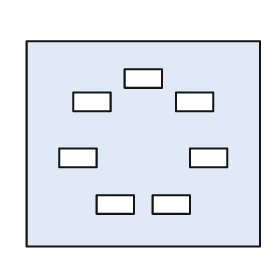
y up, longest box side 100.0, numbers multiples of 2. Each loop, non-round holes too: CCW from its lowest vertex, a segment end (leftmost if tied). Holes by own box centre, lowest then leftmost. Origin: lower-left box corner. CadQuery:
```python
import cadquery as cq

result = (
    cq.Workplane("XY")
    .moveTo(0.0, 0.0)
    .lineTo(100.0, 0.0)
    .lineTo(100.0, 88.0)
    .lineTo(0.0, 88.0)
    .close()
    .moveTo(30.0, 14.0)
    .lineTo(46.0, 14.0)
    .lineTo(46.0, 22.0)
    .lineTo(30.0, 22.0)
    .close()
    .moveTo(54.0, 14.0)
    .lineTo(70.0, 14.0)
    .lineTo(70.0, 22.0)
    .lineTo(54.0, 22.0)
    .close()
    .moveTo(14.0, 34.0)
    .lineTo(30.0, 34.0)
    .lineTo(30.0, 42.0)
    .lineTo(14.0, 42.0)
    .close()
    .moveTo(70.0, 34.0)
    .lineTo(86.0, 34.0)
    .lineTo(86.0, 42.0)
    .lineTo(70.0, 42.0)
    .close()
    .moveTo(20.0, 58.0)
    .lineTo(36.0, 58.0)
    .lineTo(36.0, 66.0)
    .lineTo(20.0, 66.0)
    .close()
    .moveTo(64.0, 58.0)
    .lineTo(80.0, 58.0)
    .lineTo(80.0, 66.0)
    .lineTo(64.0, 66.0)
    .close()
    .moveTo(42.0, 68.0)
    .lineTo(58.0, 68.0)
    .lineTo(58.0, 76.0)
    .lineTo(42.0, 76.0)
    .close()
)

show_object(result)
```